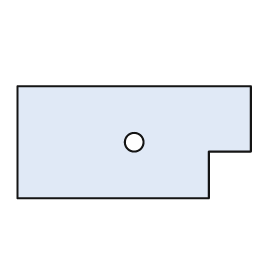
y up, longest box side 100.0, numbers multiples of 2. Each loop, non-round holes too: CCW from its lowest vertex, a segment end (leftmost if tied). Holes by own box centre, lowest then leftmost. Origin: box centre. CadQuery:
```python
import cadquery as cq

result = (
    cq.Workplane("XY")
    .moveTo(-50.0, -24.0)
    .lineTo(32.0, -24.0)
    .lineTo(32.0, -4.0)
    .lineTo(50.0, -4.0)
    .lineTo(50.0, 24.0)
    .lineTo(-50.0, 24.0)
    .close()
    .moveTo(0.0, 0.0)
    .circle(4.0)
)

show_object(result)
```